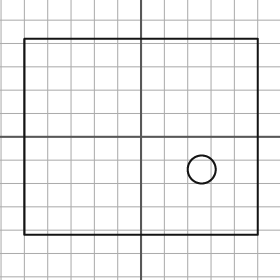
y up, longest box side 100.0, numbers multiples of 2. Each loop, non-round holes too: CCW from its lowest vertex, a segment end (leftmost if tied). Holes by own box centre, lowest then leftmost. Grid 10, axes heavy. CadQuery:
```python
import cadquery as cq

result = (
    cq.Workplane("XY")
    .moveTo(-50.0, -42.0)
    .lineTo(50.0, -42.0)
    .lineTo(50.0, 42.0)
    .lineTo(-50.0, 42.0)
    .close()
    .moveTo(26.0, -14.0)
    .circle(6.0)
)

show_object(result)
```